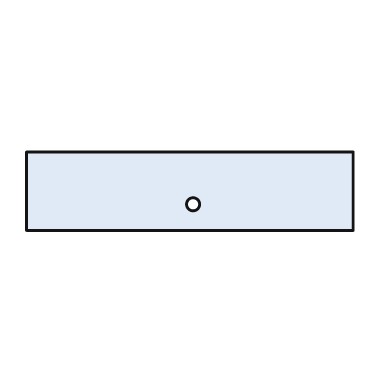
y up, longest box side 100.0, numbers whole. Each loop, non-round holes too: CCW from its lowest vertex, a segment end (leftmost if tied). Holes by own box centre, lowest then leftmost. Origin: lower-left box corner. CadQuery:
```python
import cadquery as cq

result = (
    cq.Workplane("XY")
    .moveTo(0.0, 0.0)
    .lineTo(100.0, 0.0)
    .lineTo(100.0, 24.0)
    .lineTo(0.0, 24.0)
    .close()
    .moveTo(51.0, 8.0)
    .circle(2.0)
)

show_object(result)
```